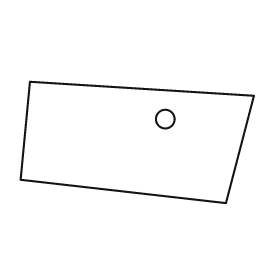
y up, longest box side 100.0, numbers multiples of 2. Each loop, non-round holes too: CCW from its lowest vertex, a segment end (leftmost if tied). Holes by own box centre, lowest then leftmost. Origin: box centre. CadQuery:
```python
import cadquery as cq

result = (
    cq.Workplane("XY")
    .moveTo(38.0, -26.0)
    .lineTo(50.0, 20.0)
    .lineTo(-46.0, 26.0)
    .lineTo(-50.0, -16.0)
    .close()
    .moveTo(12.0, 10.0)
    .circle(4.0)
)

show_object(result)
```